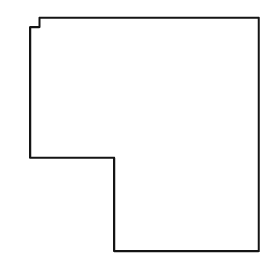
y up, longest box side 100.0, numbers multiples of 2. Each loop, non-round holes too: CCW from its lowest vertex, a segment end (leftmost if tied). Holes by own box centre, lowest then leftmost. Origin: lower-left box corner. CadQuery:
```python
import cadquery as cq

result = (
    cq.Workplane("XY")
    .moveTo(36.0, 0.0)
    .lineTo(98.0, 0.0)
    .lineTo(98.0, 100.0)
    .lineTo(4.0, 100.0)
    .lineTo(4.0, 96.0)
    .lineTo(0.0, 96.0)
    .lineTo(0.0, 40.0)
    .lineTo(36.0, 40.0)
    .close()
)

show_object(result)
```